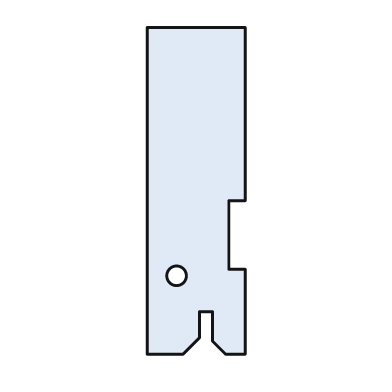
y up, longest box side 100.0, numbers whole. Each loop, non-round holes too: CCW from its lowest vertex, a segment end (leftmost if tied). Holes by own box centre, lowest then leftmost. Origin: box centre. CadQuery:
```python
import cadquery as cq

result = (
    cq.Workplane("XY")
    .moveTo(-15.0, -50.0)
    .lineTo(-4.0, -50.0)
    .lineTo(1.0, -45.0)
    .lineTo(1.0, -37.0)
    .lineTo(5.0, -37.0)
    .lineTo(5.0, -46.0)
    .lineTo(9.0, -50.0)
    .lineTo(15.0, -50.0)
    .lineTo(15.0, -24.0)
    .lineTo(10.0, -24.0)
    .lineTo(10.0, -3.0)
    .lineTo(15.0, -3.0)
    .lineTo(15.0, 50.0)
    .lineTo(-15.0, 50.0)
    .close()
    .moveTo(-6.0, -26.0)
    .circle(3.0)
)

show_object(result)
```